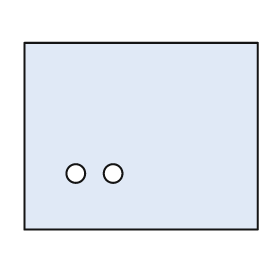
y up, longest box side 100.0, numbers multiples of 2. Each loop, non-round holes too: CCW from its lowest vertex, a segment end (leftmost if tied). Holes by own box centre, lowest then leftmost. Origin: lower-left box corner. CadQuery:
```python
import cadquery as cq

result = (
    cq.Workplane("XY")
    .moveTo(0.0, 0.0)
    .lineTo(100.0, 0.0)
    .lineTo(100.0, 80.0)
    .lineTo(0.0, 80.0)
    .close()
    .moveTo(22.0, 24.0)
    .circle(4.0)
    .moveTo(38.0, 24.0)
    .circle(4.0)
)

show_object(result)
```